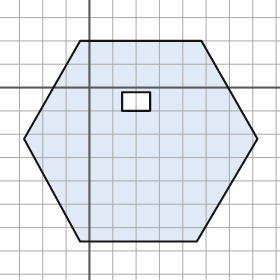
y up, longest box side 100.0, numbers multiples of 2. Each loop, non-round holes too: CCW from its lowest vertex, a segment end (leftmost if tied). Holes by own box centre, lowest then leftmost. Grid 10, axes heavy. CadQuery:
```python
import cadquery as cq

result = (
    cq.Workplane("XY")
    .moveTo(-4.0, -66.0)
    .lineTo(46.0, -66.0)
    .lineTo(72.0, -22.0)
    .lineTo(48.0, 20.0)
    .lineTo(-4.0, 20.0)
    .lineTo(-28.0, -22.0)
    .close()
    .moveTo(14.0, -10.0)
    .lineTo(26.0, -10.0)
    .lineTo(26.0, -2.0)
    .lineTo(14.0, -2.0)
    .close()
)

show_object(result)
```